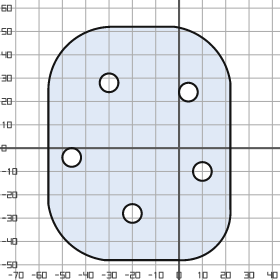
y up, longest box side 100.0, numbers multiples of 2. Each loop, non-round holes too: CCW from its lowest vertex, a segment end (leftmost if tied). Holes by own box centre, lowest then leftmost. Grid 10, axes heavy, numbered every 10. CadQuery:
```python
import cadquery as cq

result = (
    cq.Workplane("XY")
    .moveTo(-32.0, -48.0)
    .lineTo(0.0, -48.0)
    .threePointArc((16.0, -42.0), (22.0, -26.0))
    .lineTo(22.0, 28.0)
    .threePointArc((14.0, 44.0), (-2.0, 52.0))
    .lineTo(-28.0, 52.0)
    .threePointArc((-48.0, 44.0), (-56.0, 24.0))
    .lineTo(-56.0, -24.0)
    .threePointArc((-48.0, -40.0), (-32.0, -48.0))
    .close()
    .moveTo(-20.0, -28.0)
    .circle(4.0)
    .moveTo(10.0, -10.0)
    .circle(4.0)
    .moveTo(-46.0, -4.0)
    .circle(4.0)
    .moveTo(4.0, 24.0)
    .circle(4.0)
    .moveTo(-30.0, 28.0)
    .circle(4.0)
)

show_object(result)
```